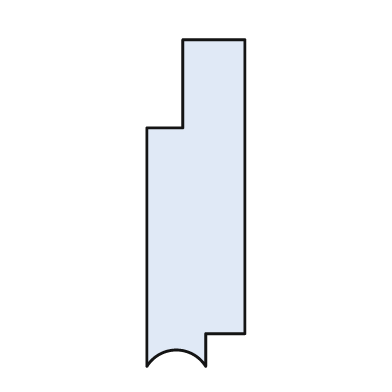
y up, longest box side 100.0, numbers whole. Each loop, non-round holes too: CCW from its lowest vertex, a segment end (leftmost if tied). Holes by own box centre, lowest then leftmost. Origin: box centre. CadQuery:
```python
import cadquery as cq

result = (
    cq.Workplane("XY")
    .moveTo(-15.0, -50.0)
    .threePointArc((-6.0, -45.0), (3.0, -50.0))
    .lineTo(3.0, -40.0)
    .lineTo(15.0, -40.0)
    .lineTo(15.0, 50.0)
    .lineTo(-4.0, 50.0)
    .lineTo(-4.0, 23.0)
    .lineTo(-15.0, 23.0)
    .close()
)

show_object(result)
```